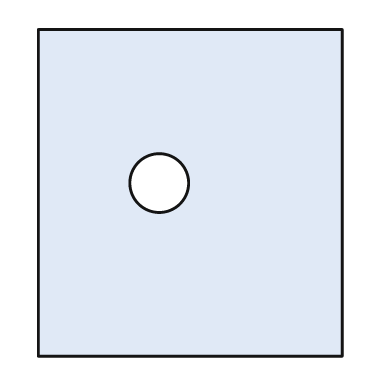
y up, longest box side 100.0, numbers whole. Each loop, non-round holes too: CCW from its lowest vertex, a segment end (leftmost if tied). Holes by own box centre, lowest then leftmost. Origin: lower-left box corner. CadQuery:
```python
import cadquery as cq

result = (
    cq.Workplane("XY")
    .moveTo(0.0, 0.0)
    .lineTo(93.0, 0.0)
    .lineTo(93.0, 100.0)
    .lineTo(0.0, 100.0)
    .close()
    .moveTo(37.0, 53.0)
    .circle(9.0)
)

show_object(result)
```